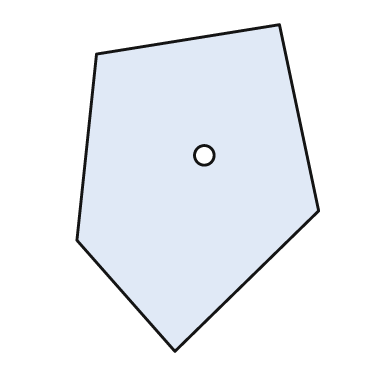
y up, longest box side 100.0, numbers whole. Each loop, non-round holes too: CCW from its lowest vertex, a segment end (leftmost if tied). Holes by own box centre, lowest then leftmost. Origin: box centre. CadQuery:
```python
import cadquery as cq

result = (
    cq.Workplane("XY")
    .moveTo(-7.0, -50.0)
    .lineTo(37.0, -7.0)
    .lineTo(25.0, 50.0)
    .lineTo(-31.0, 41.0)
    .lineTo(-37.0, -16.0)
    .close()
    .moveTo(2.0, 10.0)
    .circle(3.0)
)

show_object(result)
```